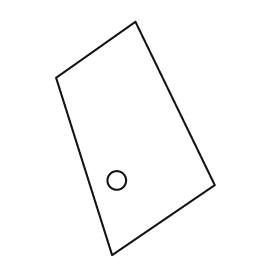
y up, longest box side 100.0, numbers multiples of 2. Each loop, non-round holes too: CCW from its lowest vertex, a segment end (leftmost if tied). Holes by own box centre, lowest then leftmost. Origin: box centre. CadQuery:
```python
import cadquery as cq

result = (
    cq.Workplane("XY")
    .moveTo(-10.0, -50.0)
    .lineTo(34.0, -20.0)
    .lineTo(0.0, 50.0)
    .lineTo(-34.0, 26.0)
    .close()
    .moveTo(-8.0, -18.0)
    .circle(4.0)
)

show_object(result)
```